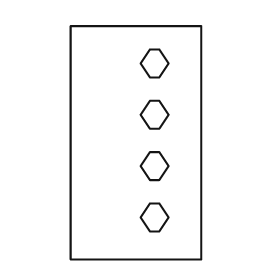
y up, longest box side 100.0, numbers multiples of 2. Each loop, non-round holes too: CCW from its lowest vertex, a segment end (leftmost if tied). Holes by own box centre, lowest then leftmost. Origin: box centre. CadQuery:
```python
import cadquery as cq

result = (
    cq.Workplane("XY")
    .moveTo(-28.0, -50.0)
    .lineTo(28.0, -50.0)
    .lineTo(28.0, 50.0)
    .lineTo(-28.0, 50.0)
    .close()
    .moveTo(6.0, -38.0)
    .lineTo(10.0, -38.0)
    .lineTo(14.0, -32.0)
    .lineTo(10.0, -26.0)
    .lineTo(6.0, -26.0)
    .lineTo(2.0, -32.0)
    .close()
    .moveTo(6.0, -16.0)
    .lineTo(10.0, -16.0)
    .lineTo(14.0, -10.0)
    .lineTo(10.0, -4.0)
    .lineTo(6.0, -4.0)
    .lineTo(2.0, -10.0)
    .close()
    .moveTo(6.0, 6.0)
    .lineTo(10.0, 6.0)
    .lineTo(14.0, 12.0)
    .lineTo(10.0, 18.0)
    .lineTo(6.0, 18.0)
    .lineTo(2.0, 12.0)
    .close()
    .moveTo(6.0, 28.0)
    .lineTo(10.0, 28.0)
    .lineTo(14.0, 34.0)
    .lineTo(10.0, 40.0)
    .lineTo(6.0, 40.0)
    .lineTo(2.0, 34.0)
    .close()
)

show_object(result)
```